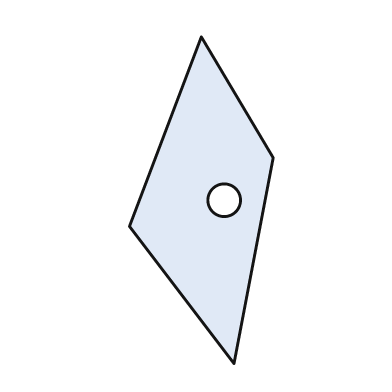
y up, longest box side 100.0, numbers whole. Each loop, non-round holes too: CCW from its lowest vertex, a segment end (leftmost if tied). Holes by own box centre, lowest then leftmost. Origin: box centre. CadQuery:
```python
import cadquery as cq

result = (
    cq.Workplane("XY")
    .moveTo(10.0, -50.0)
    .lineTo(22.0, 13.0)
    .lineTo(0.0, 50.0)
    .lineTo(-22.0, -8.0)
    .close()
    .moveTo(7.0, 0.0)
    .circle(5.0)
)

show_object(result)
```